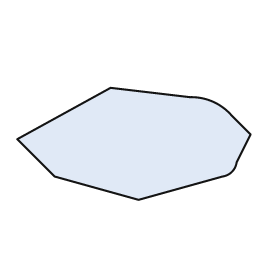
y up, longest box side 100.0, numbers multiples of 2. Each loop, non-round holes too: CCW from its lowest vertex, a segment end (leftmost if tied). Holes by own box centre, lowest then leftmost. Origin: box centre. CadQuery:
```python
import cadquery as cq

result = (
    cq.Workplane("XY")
    .moveTo(2.0, -24.0)
    .lineTo(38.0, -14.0)
    .threePointArc((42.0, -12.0), (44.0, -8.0))
    .lineTo(50.0, 4.0)
    .lineTo(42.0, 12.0)
    .threePointArc((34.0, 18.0), (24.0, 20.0))
    .lineTo(-10.0, 24.0)
    .lineTo(-50.0, 2.0)
    .lineTo(-34.0, -14.0)
    .close()
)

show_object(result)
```